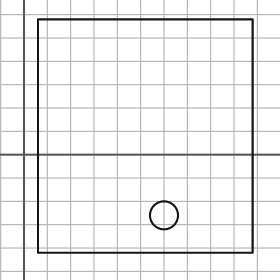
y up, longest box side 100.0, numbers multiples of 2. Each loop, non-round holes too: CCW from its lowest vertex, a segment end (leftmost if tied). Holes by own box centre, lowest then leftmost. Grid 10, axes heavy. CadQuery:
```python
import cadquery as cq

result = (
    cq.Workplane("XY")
    .moveTo(6.0, -42.0)
    .lineTo(98.0, -42.0)
    .lineTo(98.0, 58.0)
    .lineTo(6.0, 58.0)
    .close()
    .moveTo(60.0, -26.0)
    .circle(6.0)
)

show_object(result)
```